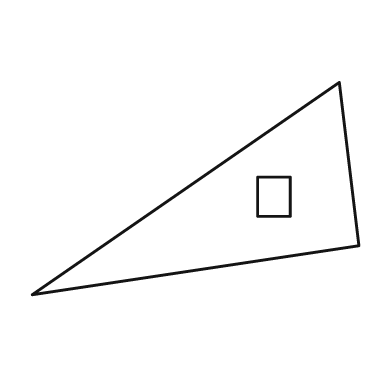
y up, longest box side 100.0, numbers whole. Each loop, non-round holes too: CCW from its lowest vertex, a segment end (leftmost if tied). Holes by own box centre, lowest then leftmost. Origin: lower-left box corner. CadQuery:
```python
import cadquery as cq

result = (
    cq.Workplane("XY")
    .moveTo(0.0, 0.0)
    .lineTo(100.0, 15.0)
    .lineTo(94.0, 65.0)
    .close()
    .moveTo(69.0, 24.0)
    .lineTo(79.0, 24.0)
    .lineTo(79.0, 36.0)
    .lineTo(69.0, 36.0)
    .close()
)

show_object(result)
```